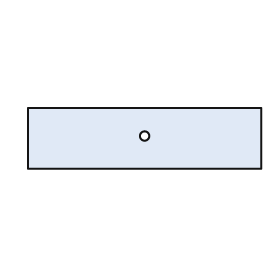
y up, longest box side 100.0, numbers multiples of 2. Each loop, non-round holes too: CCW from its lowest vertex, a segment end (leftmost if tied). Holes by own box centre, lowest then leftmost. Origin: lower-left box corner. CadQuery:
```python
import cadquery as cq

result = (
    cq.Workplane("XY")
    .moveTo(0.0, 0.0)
    .lineTo(100.0, 0.0)
    .lineTo(100.0, 26.0)
    .lineTo(0.0, 26.0)
    .close()
    .moveTo(50.0, 14.0)
    .circle(2.0)
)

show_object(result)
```